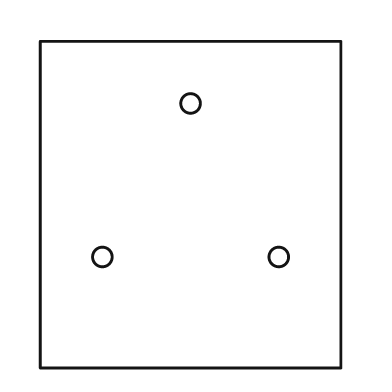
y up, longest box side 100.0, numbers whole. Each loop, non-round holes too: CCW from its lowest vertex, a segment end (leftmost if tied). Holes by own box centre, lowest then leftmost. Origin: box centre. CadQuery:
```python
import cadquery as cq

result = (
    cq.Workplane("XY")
    .moveTo(-46.0, -50.0)
    .lineTo(46.0, -50.0)
    .lineTo(46.0, 50.0)
    .lineTo(-46.0, 50.0)
    .close()
    .moveTo(-27.0, -16.0)
    .circle(3.0)
    .moveTo(27.0, -16.0)
    .circle(3.0)
    .moveTo(0.0, 31.0)
    .circle(3.0)
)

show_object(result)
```